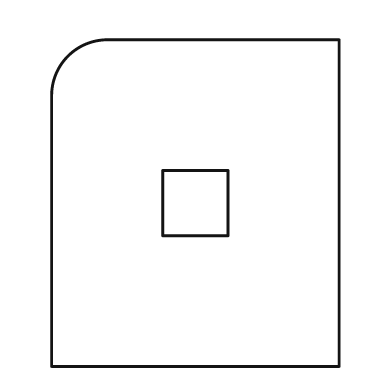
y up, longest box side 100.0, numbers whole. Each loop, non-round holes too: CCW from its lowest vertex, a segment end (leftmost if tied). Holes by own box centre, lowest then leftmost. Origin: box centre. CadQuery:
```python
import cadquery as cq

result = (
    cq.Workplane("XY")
    .moveTo(-44.0, -50.0)
    .lineTo(44.0, -50.0)
    .lineTo(44.0, 50.0)
    .lineTo(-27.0, 50.0)
    .threePointArc((-39.0, 45.0), (-44.0, 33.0))
    .close()
    .moveTo(-10.0, -10.0)
    .lineTo(10.0, -10.0)
    .lineTo(10.0, 10.0)
    .lineTo(-10.0, 10.0)
    .close()
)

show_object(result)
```